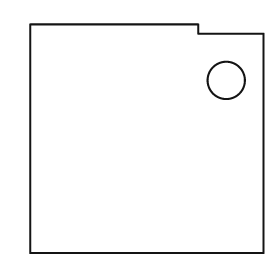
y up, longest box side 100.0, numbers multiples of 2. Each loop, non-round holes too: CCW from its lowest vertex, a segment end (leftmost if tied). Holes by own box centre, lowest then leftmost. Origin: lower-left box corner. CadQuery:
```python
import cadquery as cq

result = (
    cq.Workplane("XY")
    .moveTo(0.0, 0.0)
    .lineTo(100.0, 0.0)
    .lineTo(100.0, 94.0)
    .lineTo(72.0, 94.0)
    .lineTo(72.0, 98.0)
    .lineTo(0.0, 98.0)
    .close()
    .moveTo(84.0, 74.0)
    .circle(8.0)
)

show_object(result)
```